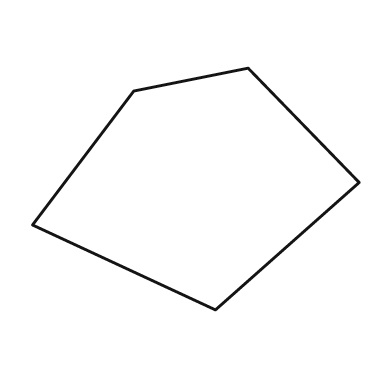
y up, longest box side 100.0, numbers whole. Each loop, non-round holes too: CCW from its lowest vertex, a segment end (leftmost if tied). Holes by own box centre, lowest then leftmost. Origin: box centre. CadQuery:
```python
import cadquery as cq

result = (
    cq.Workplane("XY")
    .moveTo(6.0, -37.0)
    .lineTo(50.0, 2.0)
    .lineTo(16.0, 37.0)
    .lineTo(-19.0, 30.0)
    .lineTo(-50.0, -11.0)
    .close()
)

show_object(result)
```